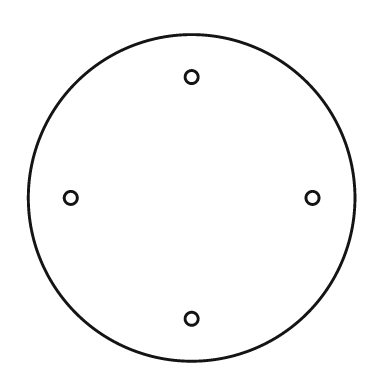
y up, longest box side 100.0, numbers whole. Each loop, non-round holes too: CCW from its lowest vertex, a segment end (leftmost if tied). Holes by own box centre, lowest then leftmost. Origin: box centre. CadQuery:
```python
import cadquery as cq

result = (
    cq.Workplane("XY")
    .moveTo(0.0, 0.0)
    .circle(50.0)
    .moveTo(0.0, -37.0)
    .circle(2.0)
    .moveTo(-37.0, 0.0)
    .circle(2.0)
    .moveTo(37.0, 0.0)
    .circle(2.0)
    .moveTo(0.0, 37.0)
    .circle(2.0)
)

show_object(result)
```